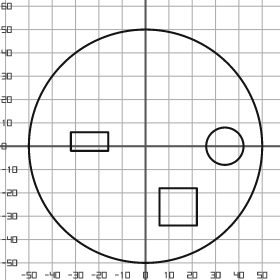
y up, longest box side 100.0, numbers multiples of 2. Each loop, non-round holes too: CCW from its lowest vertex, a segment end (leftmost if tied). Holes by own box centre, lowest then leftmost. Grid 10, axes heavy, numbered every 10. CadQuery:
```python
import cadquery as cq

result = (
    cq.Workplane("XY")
    .moveTo(0.0, 0.0)
    .circle(50.0)
    .moveTo(6.0, -34.0)
    .lineTo(22.0, -34.0)
    .lineTo(22.0, -18.0)
    .lineTo(6.0, -18.0)
    .close()
    .moveTo(34.0, 0.0)
    .circle(8.0)
    .moveTo(-32.0, -2.0)
    .lineTo(-16.0, -2.0)
    .lineTo(-16.0, 6.0)
    .lineTo(-32.0, 6.0)
    .close()
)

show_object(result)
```